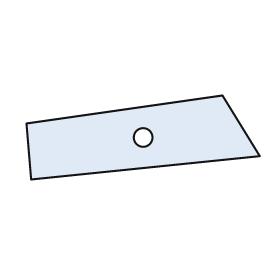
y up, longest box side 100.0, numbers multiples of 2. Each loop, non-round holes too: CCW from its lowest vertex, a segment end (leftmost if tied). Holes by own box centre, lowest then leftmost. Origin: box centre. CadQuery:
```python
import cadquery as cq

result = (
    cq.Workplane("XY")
    .moveTo(-48.0, -18.0)
    .lineTo(50.0, -8.0)
    .lineTo(34.0, 18.0)
    .lineTo(-50.0, 6.0)
    .close()
    .moveTo(0.0, 0.0)
    .circle(4.0)
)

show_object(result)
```